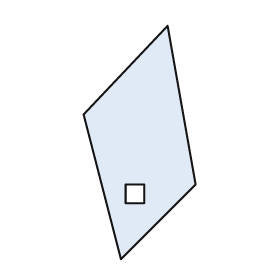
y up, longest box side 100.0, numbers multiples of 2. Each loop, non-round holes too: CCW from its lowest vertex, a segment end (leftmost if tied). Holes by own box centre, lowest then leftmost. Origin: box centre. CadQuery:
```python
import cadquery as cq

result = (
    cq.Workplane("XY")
    .moveTo(-8.0, -50.0)
    .lineTo(24.0, -18.0)
    .lineTo(12.0, 50.0)
    .lineTo(-24.0, 12.0)
    .close()
    .moveTo(-6.0, -26.0)
    .lineTo(2.0, -26.0)
    .lineTo(2.0, -18.0)
    .lineTo(-6.0, -18.0)
    .close()
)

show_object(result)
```